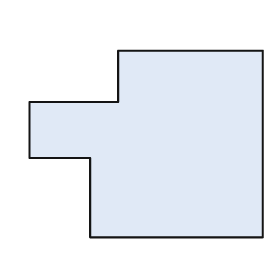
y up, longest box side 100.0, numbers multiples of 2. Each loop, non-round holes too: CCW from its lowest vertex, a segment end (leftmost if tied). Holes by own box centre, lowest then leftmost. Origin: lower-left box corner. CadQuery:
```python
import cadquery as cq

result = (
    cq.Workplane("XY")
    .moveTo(26.0, 0.0)
    .lineTo(100.0, 0.0)
    .lineTo(100.0, 80.0)
    .lineTo(38.0, 80.0)
    .lineTo(38.0, 58.0)
    .lineTo(0.0, 58.0)
    .lineTo(0.0, 34.0)
    .lineTo(26.0, 34.0)
    .close()
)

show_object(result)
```